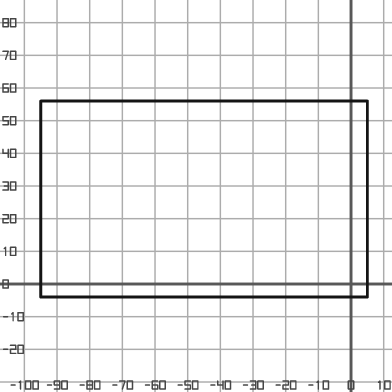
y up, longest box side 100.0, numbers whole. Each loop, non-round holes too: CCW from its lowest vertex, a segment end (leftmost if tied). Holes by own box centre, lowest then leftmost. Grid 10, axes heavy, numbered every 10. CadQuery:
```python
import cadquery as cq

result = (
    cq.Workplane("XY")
    .moveTo(-95.0, -4.0)
    .lineTo(5.0, -4.0)
    .lineTo(5.0, 56.0)
    .lineTo(-95.0, 56.0)
    .close()
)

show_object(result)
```